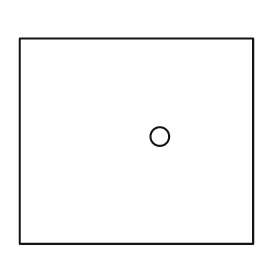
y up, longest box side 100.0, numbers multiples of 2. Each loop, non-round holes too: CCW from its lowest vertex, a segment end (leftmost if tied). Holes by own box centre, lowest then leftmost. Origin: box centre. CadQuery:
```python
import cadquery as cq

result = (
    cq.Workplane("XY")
    .moveTo(-50.0, -44.0)
    .lineTo(50.0, -44.0)
    .lineTo(50.0, 44.0)
    .lineTo(-50.0, 44.0)
    .close()
    .moveTo(10.0, 2.0)
    .circle(4.0)
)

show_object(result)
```